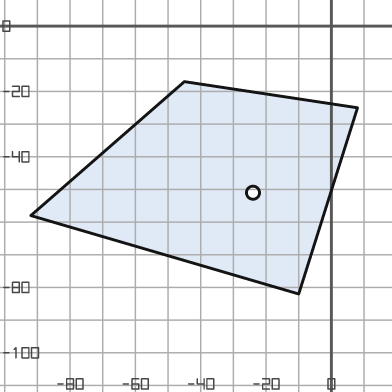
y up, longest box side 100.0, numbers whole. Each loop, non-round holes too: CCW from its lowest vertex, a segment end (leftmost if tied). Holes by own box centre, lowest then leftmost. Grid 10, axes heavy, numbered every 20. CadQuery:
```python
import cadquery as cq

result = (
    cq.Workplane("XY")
    .moveTo(-10.0, -82.0)
    .lineTo(8.0, -25.0)
    .lineTo(-45.0, -17.0)
    .lineTo(-92.0, -58.0)
    .close()
    .moveTo(-24.0, -51.0)
    .circle(2.0)
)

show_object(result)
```